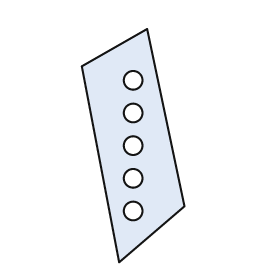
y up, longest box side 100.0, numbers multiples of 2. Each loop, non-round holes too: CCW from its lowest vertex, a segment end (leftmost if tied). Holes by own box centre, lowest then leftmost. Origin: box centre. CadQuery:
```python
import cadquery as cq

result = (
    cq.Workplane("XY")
    .moveTo(-6.0, -50.0)
    .lineTo(22.0, -26.0)
    .lineTo(6.0, 50.0)
    .lineTo(-22.0, 34.0)
    .close()
    .moveTo(0.0, -28.0)
    .circle(4.0)
    .moveTo(0.0, -14.0)
    .circle(4.0)
    .moveTo(0.0, 0.0)
    .circle(4.0)
    .moveTo(0.0, 14.0)
    .circle(4.0)
    .moveTo(0.0, 28.0)
    .circle(4.0)
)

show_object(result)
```